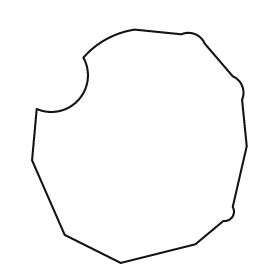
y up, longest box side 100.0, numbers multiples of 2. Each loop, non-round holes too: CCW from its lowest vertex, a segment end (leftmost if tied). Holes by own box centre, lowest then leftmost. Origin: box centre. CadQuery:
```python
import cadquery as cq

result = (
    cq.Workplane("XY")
    .moveTo(-8.0, -50.0)
    .lineTo(24.0, -42.0)
    .lineTo(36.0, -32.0)
    .threePointArc((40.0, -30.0), (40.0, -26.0))
    .lineTo(46.0, 0.0)
    .lineTo(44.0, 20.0)
    .threePointArc((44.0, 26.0), (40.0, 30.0))
    .lineTo(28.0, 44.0)
    .threePointArc((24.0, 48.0), (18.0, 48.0))
    .lineTo(-2.0, 50.0)
    .threePointArc((-14.0, 46.0), (-24.0, 38.0))
    .threePointArc((-26.0, 20.0), (-44.0, 16.0))
    .lineTo(-46.0, -6.0)
    .lineTo(-32.0, -38.0)
    .close()
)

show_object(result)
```